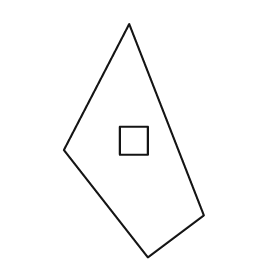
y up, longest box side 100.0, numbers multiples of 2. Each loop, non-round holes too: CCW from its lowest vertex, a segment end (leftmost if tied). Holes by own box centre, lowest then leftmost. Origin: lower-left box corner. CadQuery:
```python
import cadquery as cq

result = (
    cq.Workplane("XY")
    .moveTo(36.0, 0.0)
    .lineTo(60.0, 18.0)
    .lineTo(28.0, 100.0)
    .lineTo(0.0, 46.0)
    .close()
    .moveTo(24.0, 44.0)
    .lineTo(36.0, 44.0)
    .lineTo(36.0, 56.0)
    .lineTo(24.0, 56.0)
    .close()
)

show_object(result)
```